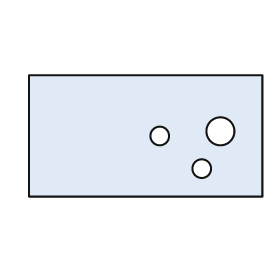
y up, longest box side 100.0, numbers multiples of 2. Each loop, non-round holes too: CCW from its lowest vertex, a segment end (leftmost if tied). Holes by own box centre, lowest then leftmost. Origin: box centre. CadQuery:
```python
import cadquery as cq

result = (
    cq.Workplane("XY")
    .moveTo(-50.0, -26.0)
    .lineTo(50.0, -26.0)
    .lineTo(50.0, 26.0)
    .lineTo(-50.0, 26.0)
    .close()
    .moveTo(24.0, -14.0)
    .circle(4.0)
    .moveTo(6.0, 0.0)
    .circle(4.0)
    .moveTo(32.0, 2.0)
    .circle(6.0)
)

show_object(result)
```